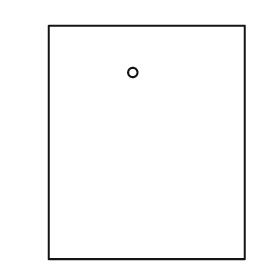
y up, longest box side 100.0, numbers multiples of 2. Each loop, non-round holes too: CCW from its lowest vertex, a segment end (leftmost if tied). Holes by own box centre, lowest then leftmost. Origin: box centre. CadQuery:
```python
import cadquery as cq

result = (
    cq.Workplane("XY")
    .moveTo(-42.0, -50.0)
    .lineTo(42.0, -50.0)
    .lineTo(42.0, 50.0)
    .lineTo(-42.0, 50.0)
    .close()
    .moveTo(-6.0, 30.0)
    .circle(2.0)
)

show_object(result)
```